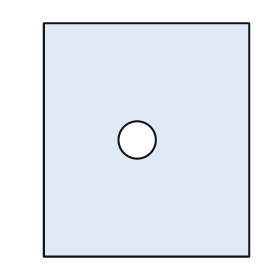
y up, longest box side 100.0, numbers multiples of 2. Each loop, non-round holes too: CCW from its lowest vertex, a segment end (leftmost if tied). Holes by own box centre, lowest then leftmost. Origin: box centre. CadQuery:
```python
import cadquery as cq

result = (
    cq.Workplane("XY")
    .moveTo(-44.0, -50.0)
    .lineTo(44.0, -50.0)
    .lineTo(44.0, 50.0)
    .lineTo(-44.0, 50.0)
    .close()
    .moveTo(-4.0, 0.0)
    .circle(8.0)
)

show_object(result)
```